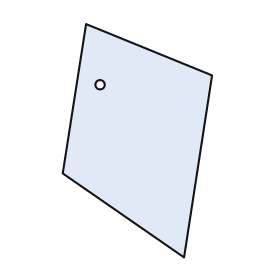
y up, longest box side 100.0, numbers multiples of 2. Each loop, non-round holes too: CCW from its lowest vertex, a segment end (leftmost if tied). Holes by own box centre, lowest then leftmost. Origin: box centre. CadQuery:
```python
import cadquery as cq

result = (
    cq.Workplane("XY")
    .moveTo(20.0, -50.0)
    .lineTo(32.0, 28.0)
    .lineTo(-22.0, 50.0)
    .lineTo(-32.0, -14.0)
    .close()
    .moveTo(-16.0, 24.0)
    .circle(2.0)
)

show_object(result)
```